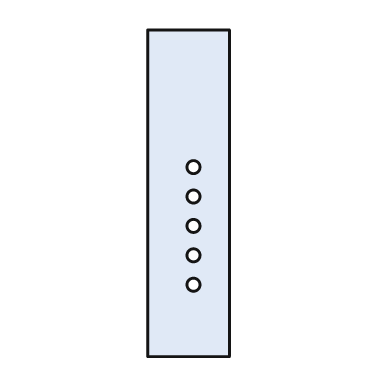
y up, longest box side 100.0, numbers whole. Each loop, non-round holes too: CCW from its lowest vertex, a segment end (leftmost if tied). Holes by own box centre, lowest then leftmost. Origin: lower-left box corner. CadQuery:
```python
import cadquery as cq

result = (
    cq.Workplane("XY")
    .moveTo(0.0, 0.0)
    .lineTo(25.0, 0.0)
    .lineTo(25.0, 100.0)
    .lineTo(0.0, 100.0)
    .close()
    .moveTo(14.0, 22.0)
    .circle(2.0)
    .moveTo(14.0, 31.0)
    .circle(2.0)
    .moveTo(14.0, 40.0)
    .circle(2.0)
    .moveTo(14.0, 49.0)
    .circle(2.0)
    .moveTo(14.0, 58.0)
    .circle(2.0)
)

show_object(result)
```